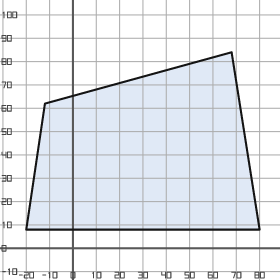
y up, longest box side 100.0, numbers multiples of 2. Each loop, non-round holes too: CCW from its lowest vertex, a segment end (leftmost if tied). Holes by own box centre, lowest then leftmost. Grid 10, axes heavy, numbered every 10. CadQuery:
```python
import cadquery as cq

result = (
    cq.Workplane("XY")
    .moveTo(-20.0, 8.0)
    .lineTo(80.0, 8.0)
    .lineTo(68.0, 84.0)
    .lineTo(-12.0, 62.0)
    .close()
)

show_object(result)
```